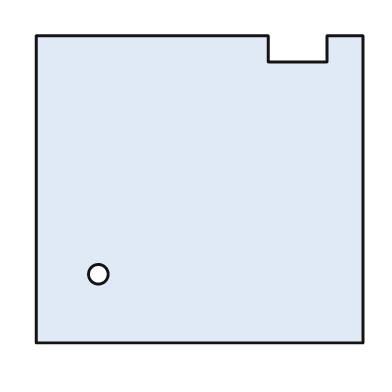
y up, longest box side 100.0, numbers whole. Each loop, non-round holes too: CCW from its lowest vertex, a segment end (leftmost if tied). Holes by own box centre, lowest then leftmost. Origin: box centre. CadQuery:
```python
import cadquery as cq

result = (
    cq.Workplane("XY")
    .moveTo(-50.0, -47.0)
    .lineTo(50.0, -47.0)
    .lineTo(50.0, 47.0)
    .lineTo(39.0, 47.0)
    .lineTo(39.0, 39.0)
    .lineTo(21.0, 39.0)
    .lineTo(21.0, 47.0)
    .lineTo(-50.0, 47.0)
    .close()
    .moveTo(-31.0, -26.0)
    .circle(3.0)
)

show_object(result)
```